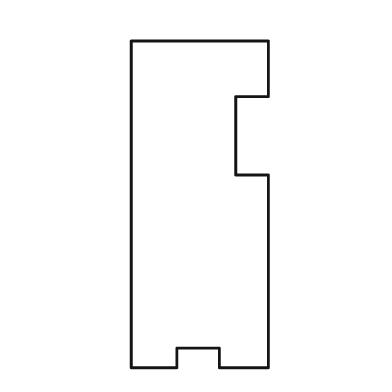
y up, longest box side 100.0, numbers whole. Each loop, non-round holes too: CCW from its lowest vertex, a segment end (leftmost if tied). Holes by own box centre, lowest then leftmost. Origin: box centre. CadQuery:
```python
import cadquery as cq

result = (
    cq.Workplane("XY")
    .moveTo(-21.0, -50.0)
    .lineTo(-7.0, -50.0)
    .lineTo(-7.0, -44.0)
    .lineTo(6.0, -44.0)
    .lineTo(6.0, -50.0)
    .lineTo(21.0, -50.0)
    .lineTo(21.0, 9.0)
    .lineTo(11.0, 9.0)
    .lineTo(11.0, 33.0)
    .lineTo(21.0, 33.0)
    .lineTo(21.0, 50.0)
    .lineTo(-21.0, 50.0)
    .close()
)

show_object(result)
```